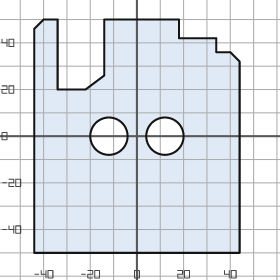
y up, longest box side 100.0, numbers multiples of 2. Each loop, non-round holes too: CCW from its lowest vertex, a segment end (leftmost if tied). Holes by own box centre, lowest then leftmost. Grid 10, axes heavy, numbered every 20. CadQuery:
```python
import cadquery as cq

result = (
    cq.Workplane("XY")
    .moveTo(-44.0, -50.0)
    .lineTo(44.0, -50.0)
    .lineTo(44.0, 32.0)
    .lineTo(40.0, 36.0)
    .lineTo(34.0, 36.0)
    .lineTo(34.0, 42.0)
    .lineTo(18.0, 42.0)
    .lineTo(18.0, 50.0)
    .lineTo(-14.0, 50.0)
    .lineTo(-14.0, 26.0)
    .lineTo(-22.0, 20.0)
    .lineTo(-34.0, 20.0)
    .lineTo(-34.0, 50.0)
    .lineTo(-40.0, 50.0)
    .lineTo(-44.0, 46.0)
    .close()
    .moveTo(-12.0, 0.0)
    .circle(8.0)
    .moveTo(12.0, 0.0)
    .circle(8.0)
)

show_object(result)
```